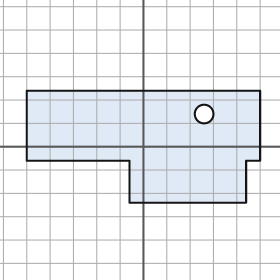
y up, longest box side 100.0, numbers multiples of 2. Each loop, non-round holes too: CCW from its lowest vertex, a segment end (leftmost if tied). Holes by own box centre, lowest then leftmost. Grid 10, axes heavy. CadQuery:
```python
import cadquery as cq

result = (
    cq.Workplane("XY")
    .moveTo(-6.0, -24.0)
    .lineTo(44.0, -24.0)
    .lineTo(44.0, -6.0)
    .lineTo(50.0, -6.0)
    .lineTo(50.0, 24.0)
    .lineTo(-50.0, 24.0)
    .lineTo(-50.0, -6.0)
    .lineTo(-6.0, -6.0)
    .close()
    .moveTo(26.0, 14.0)
    .circle(4.0)
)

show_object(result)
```